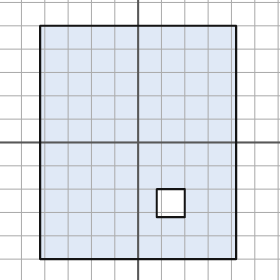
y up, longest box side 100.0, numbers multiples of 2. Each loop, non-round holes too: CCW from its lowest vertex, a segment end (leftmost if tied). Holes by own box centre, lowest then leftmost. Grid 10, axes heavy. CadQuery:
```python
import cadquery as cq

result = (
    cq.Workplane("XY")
    .moveTo(-42.0, -50.0)
    .lineTo(42.0, -50.0)
    .lineTo(42.0, 50.0)
    .lineTo(-42.0, 50.0)
    .close()
    .moveTo(8.0, -32.0)
    .lineTo(20.0, -32.0)
    .lineTo(20.0, -20.0)
    .lineTo(8.0, -20.0)
    .close()
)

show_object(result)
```